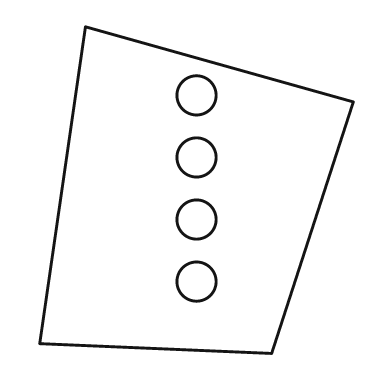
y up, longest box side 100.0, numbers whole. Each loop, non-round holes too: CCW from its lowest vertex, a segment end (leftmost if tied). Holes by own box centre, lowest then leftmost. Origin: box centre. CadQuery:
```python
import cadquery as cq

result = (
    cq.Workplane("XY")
    .moveTo(23.0, -50.0)
    .lineTo(48.0, 27.0)
    .lineTo(-34.0, 50.0)
    .lineTo(-48.0, -47.0)
    .close()
    .moveTo(0.0, -28.0)
    .circle(6.0)
    .moveTo(0.0, -9.0)
    .circle(6.0)
    .moveTo(0.0, 10.0)
    .circle(6.0)
    .moveTo(0.0, 29.0)
    .circle(6.0)
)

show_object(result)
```